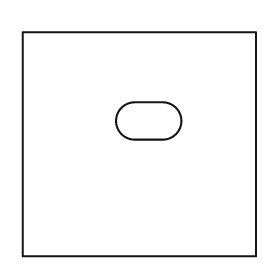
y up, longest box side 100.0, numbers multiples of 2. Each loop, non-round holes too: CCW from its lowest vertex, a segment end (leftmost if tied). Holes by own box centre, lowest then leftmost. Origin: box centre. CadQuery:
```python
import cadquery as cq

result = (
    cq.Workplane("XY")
    .moveTo(-50.0, -48.0)
    .lineTo(50.0, -48.0)
    .lineTo(50.0, 48.0)
    .lineTo(-50.0, 48.0)
    .close()
    .moveTo(-2.0, 2.0)
    .lineTo(10.0, 2.0)
    .threePointArc((18.0, 10.0), (10.0, 18.0))
    .lineTo(-2.0, 18.0)
    .threePointArc((-10.0, 10.0), (-2.0, 2.0))
    .close()
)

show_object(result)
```